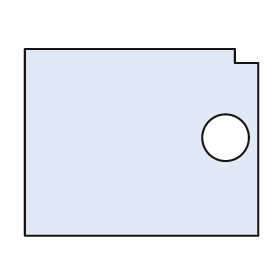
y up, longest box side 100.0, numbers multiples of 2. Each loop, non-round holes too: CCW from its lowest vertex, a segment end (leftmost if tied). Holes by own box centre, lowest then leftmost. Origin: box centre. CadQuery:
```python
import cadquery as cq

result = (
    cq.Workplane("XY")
    .moveTo(-50.0, -40.0)
    .lineTo(50.0, -40.0)
    .lineTo(50.0, 34.0)
    .lineTo(40.0, 34.0)
    .lineTo(40.0, 40.0)
    .lineTo(-50.0, 40.0)
    .close()
    .moveTo(36.0, 2.0)
    .circle(10.0)
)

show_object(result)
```